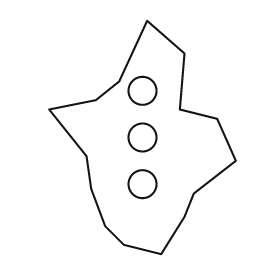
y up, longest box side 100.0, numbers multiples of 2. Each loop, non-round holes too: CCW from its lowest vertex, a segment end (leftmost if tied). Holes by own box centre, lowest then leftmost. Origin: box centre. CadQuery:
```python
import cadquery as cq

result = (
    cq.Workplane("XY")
    .moveTo(8.0, -50.0)
    .lineTo(18.0, -34.0)
    .lineTo(22.0, -24.0)
    .lineTo(40.0, -10.0)
    .lineTo(32.0, 8.0)
    .lineTo(16.0, 12.0)
    .lineTo(18.0, 36.0)
    .lineTo(2.0, 50.0)
    .lineTo(-10.0, 24.0)
    .lineTo(-20.0, 16.0)
    .lineTo(-40.0, 12.0)
    .lineTo(-24.0, -8.0)
    .lineTo(-22.0, -22.0)
    .lineTo(-16.0, -38.0)
    .lineTo(-8.0, -46.0)
    .close()
    .moveTo(0.0, -20.0)
    .circle(6.0)
    .moveTo(0.0, 0.0)
    .circle(6.0)
    .moveTo(0.0, 20.0)
    .circle(6.0)
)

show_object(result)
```